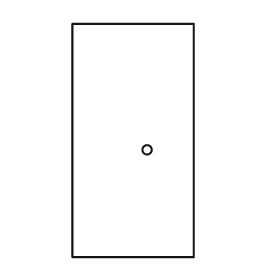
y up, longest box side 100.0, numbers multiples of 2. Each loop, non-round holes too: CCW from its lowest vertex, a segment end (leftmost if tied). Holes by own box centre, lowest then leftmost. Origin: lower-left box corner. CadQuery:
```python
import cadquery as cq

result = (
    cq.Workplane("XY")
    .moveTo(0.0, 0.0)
    .lineTo(52.0, 0.0)
    .lineTo(52.0, 100.0)
    .lineTo(0.0, 100.0)
    .close()
    .moveTo(32.0, 46.0)
    .circle(2.0)
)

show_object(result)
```